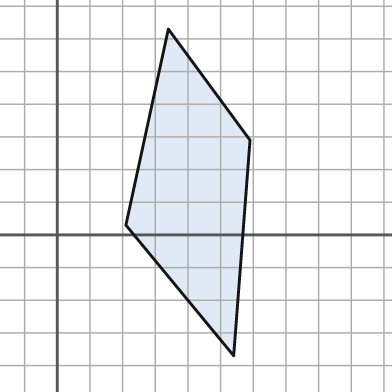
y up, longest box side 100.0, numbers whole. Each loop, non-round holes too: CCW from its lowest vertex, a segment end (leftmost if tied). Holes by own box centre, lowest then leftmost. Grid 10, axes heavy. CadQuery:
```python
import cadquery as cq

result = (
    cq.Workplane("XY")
    .moveTo(54.0, -37.0)
    .lineTo(59.0, 29.0)
    .lineTo(34.0, 63.0)
    .lineTo(21.0, 3.0)
    .close()
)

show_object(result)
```